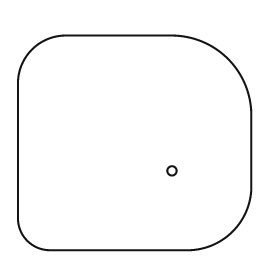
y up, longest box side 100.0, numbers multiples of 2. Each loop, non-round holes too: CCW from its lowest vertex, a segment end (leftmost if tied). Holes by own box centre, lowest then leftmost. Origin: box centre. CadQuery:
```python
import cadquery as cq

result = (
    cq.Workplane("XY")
    .moveTo(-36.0, -46.0)
    .lineTo(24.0, -46.0)
    .threePointArc((42.0, -38.0), (50.0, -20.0))
    .lineTo(50.0, 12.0)
    .threePointArc((40.0, 36.0), (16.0, 46.0))
    .lineTo(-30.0, 46.0)
    .threePointArc((-44.0, 40.0), (-50.0, 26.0))
    .lineTo(-50.0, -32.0)
    .threePointArc((-46.0, -42.0), (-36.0, -46.0))
    .close()
    .moveTo(16.0, -12.0)
    .circle(2.0)
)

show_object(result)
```